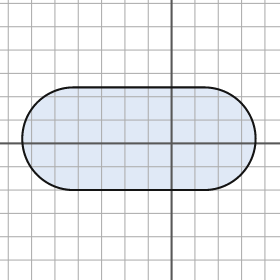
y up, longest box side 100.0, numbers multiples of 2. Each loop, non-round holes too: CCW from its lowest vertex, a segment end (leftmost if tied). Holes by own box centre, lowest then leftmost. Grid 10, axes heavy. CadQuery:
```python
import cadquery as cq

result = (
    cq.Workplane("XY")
    .moveTo(-42.0, -20.0)
    .lineTo(14.0, -20.0)
    .threePointArc((36.0, 2.0), (14.0, 24.0))
    .lineTo(-42.0, 24.0)
    .threePointArc((-64.0, 2.0), (-42.0, -20.0))
    .close()
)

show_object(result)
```